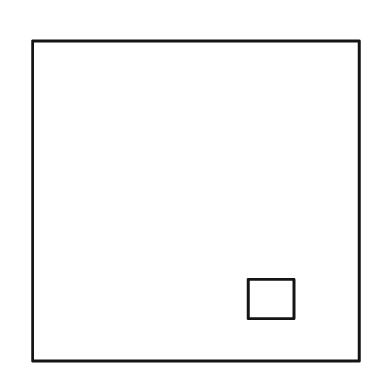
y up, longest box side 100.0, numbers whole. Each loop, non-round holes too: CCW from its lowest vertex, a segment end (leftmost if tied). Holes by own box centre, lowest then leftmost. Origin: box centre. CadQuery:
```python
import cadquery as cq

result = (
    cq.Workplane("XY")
    .moveTo(-50.0, -49.0)
    .lineTo(50.0, -49.0)
    .lineTo(50.0, 49.0)
    .lineTo(-50.0, 49.0)
    .close()
    .moveTo(16.0, -36.0)
    .lineTo(30.0, -36.0)
    .lineTo(30.0, -24.0)
    .lineTo(16.0, -24.0)
    .close()
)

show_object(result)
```